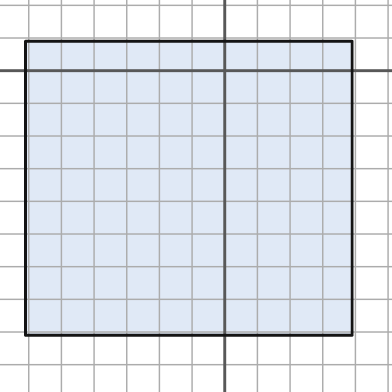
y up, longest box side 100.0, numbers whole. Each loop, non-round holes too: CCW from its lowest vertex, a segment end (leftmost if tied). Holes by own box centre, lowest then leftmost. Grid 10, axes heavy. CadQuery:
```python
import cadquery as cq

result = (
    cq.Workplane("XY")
    .moveTo(-61.0, -81.0)
    .lineTo(39.0, -81.0)
    .lineTo(39.0, 9.0)
    .lineTo(-61.0, 9.0)
    .close()
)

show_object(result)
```